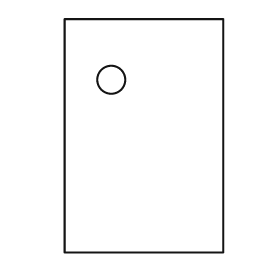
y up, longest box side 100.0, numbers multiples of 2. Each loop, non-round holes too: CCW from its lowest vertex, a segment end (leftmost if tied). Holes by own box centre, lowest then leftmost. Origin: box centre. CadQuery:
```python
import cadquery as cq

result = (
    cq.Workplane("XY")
    .moveTo(-34.0, -50.0)
    .lineTo(34.0, -50.0)
    .lineTo(34.0, 50.0)
    .lineTo(-34.0, 50.0)
    .close()
    .moveTo(-14.0, 24.0)
    .circle(6.0)
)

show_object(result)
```